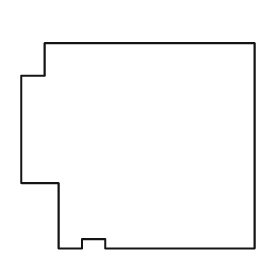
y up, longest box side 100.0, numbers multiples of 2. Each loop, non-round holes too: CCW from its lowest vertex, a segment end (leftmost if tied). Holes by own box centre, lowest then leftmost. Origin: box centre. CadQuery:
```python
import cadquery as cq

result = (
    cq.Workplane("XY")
    .moveTo(-34.0, -44.0)
    .lineTo(-24.0, -44.0)
    .lineTo(-24.0, -40.0)
    .lineTo(-14.0, -40.0)
    .lineTo(-14.0, -44.0)
    .lineTo(50.0, -44.0)
    .lineTo(50.0, 44.0)
    .lineTo(-40.0, 44.0)
    .lineTo(-40.0, 30.0)
    .lineTo(-50.0, 30.0)
    .lineTo(-50.0, -16.0)
    .lineTo(-34.0, -16.0)
    .close()
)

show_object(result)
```